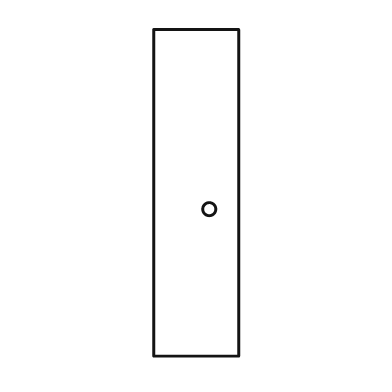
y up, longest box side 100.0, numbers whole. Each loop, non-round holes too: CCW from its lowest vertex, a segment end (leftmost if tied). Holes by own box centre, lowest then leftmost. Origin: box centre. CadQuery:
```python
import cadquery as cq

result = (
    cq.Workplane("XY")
    .moveTo(-13.0, -50.0)
    .lineTo(13.0, -50.0)
    .lineTo(13.0, 50.0)
    .lineTo(-13.0, 50.0)
    .close()
    .moveTo(4.0, -5.0)
    .circle(2.0)
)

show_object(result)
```